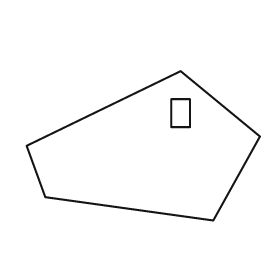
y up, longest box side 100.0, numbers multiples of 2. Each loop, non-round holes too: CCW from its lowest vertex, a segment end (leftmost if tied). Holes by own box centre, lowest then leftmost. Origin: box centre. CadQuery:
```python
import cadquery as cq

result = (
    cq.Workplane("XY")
    .moveTo(30.0, -32.0)
    .lineTo(50.0, 4.0)
    .lineTo(16.0, 32.0)
    .lineTo(-50.0, 0.0)
    .lineTo(-42.0, -22.0)
    .close()
    .moveTo(12.0, 8.0)
    .lineTo(20.0, 8.0)
    .lineTo(20.0, 20.0)
    .lineTo(12.0, 20.0)
    .close()
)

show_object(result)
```